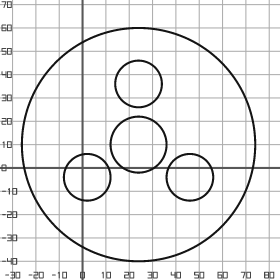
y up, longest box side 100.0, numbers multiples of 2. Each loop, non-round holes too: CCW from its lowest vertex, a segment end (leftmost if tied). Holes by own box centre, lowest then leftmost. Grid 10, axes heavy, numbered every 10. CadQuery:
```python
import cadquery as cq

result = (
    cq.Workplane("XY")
    .moveTo(24.0, 10.0)
    .circle(50.0)
    .moveTo(2.0, -4.0)
    .circle(10.0)
    .moveTo(46.0, -4.0)
    .circle(10.0)
    .moveTo(24.0, 10.0)
    .circle(12.0)
    .moveTo(24.0, 36.0)
    .circle(10.0)
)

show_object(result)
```